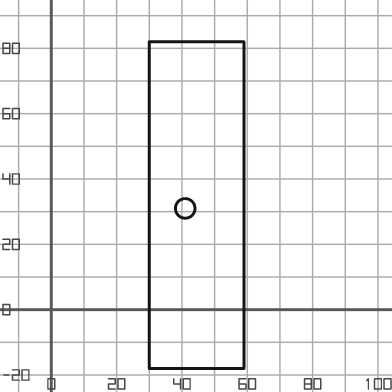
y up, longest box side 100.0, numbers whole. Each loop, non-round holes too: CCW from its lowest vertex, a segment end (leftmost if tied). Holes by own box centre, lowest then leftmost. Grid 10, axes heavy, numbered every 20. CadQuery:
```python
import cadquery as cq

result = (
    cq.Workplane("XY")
    .moveTo(30.0, -18.0)
    .lineTo(59.0, -18.0)
    .lineTo(59.0, 82.0)
    .lineTo(30.0, 82.0)
    .close()
    .moveTo(41.0, 31.0)
    .circle(3.0)
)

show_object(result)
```